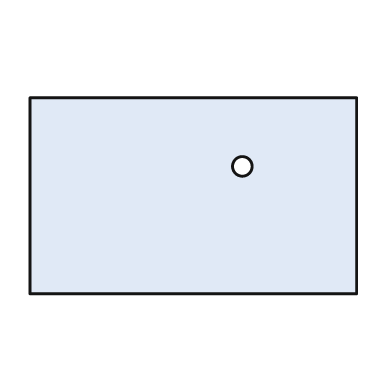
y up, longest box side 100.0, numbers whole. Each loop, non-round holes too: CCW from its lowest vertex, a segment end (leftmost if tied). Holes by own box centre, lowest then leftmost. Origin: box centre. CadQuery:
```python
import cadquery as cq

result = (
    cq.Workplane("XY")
    .moveTo(-50.0, -30.0)
    .lineTo(50.0, -30.0)
    .lineTo(50.0, 30.0)
    .lineTo(-50.0, 30.0)
    .close()
    .moveTo(15.0, 9.0)
    .circle(3.0)
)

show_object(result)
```